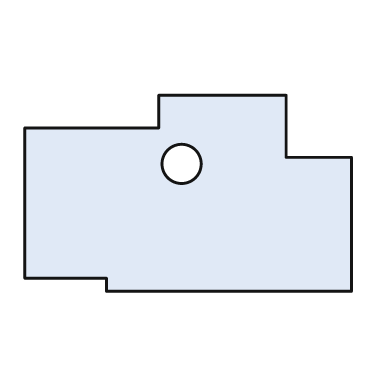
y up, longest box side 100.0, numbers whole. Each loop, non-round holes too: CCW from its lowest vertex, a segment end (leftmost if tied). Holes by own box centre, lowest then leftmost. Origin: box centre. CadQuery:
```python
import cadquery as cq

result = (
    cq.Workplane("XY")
    .moveTo(-25.0, -30.0)
    .lineTo(50.0, -30.0)
    .lineTo(50.0, 11.0)
    .lineTo(30.0, 11.0)
    .lineTo(30.0, 30.0)
    .lineTo(-9.0, 30.0)
    .lineTo(-9.0, 20.0)
    .lineTo(-50.0, 20.0)
    .lineTo(-50.0, -26.0)
    .lineTo(-25.0, -26.0)
    .close()
    .moveTo(-2.0, 9.0)
    .circle(6.0)
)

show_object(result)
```